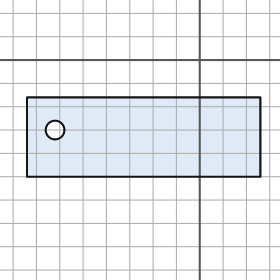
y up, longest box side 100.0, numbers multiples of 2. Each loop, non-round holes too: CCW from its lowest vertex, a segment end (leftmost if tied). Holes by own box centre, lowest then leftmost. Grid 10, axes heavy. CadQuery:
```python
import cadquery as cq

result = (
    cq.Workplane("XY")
    .moveTo(-74.0, -50.0)
    .lineTo(26.0, -50.0)
    .lineTo(26.0, -16.0)
    .lineTo(-74.0, -16.0)
    .close()
    .moveTo(-62.0, -30.0)
    .circle(4.0)
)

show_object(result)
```